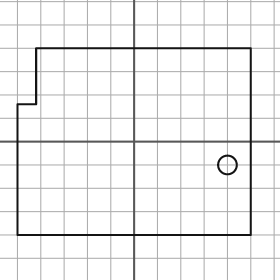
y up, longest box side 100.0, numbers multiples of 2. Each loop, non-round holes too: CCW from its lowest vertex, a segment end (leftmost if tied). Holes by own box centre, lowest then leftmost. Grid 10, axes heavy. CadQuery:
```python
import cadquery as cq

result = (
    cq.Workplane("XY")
    .moveTo(-50.0, -40.0)
    .lineTo(50.0, -40.0)
    .lineTo(50.0, 40.0)
    .lineTo(-42.0, 40.0)
    .lineTo(-42.0, 16.0)
    .lineTo(-50.0, 16.0)
    .close()
    .moveTo(40.0, -10.0)
    .circle(4.0)
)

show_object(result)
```